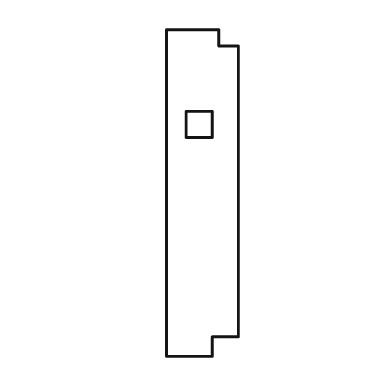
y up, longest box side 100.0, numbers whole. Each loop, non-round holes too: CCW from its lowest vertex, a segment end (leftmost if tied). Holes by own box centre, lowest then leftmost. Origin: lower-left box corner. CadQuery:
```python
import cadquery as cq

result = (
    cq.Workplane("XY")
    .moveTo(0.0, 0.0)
    .lineTo(14.0, 0.0)
    .lineTo(14.0, 6.0)
    .lineTo(22.0, 6.0)
    .lineTo(22.0, 95.0)
    .lineTo(16.0, 95.0)
    .lineTo(16.0, 100.0)
    .lineTo(0.0, 100.0)
    .close()
    .moveTo(6.0, 67.0)
    .lineTo(14.0, 67.0)
    .lineTo(14.0, 75.0)
    .lineTo(6.0, 75.0)
    .close()
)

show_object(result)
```